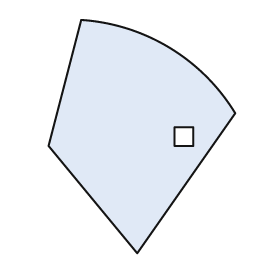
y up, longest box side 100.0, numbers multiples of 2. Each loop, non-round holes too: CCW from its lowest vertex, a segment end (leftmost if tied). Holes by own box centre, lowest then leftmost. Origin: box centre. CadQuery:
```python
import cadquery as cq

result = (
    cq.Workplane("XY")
    .moveTo(-2.0, -50.0)
    .lineTo(40.0, 10.0)
    .threePointArc((12.0, 38.0), (-26.0, 50.0))
    .lineTo(-40.0, -4.0)
    .close()
    .moveTo(14.0, -4.0)
    .lineTo(22.0, -4.0)
    .lineTo(22.0, 4.0)
    .lineTo(14.0, 4.0)
    .close()
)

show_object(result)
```